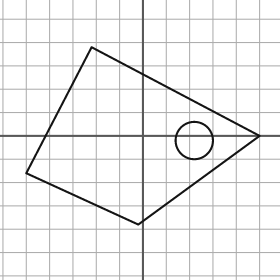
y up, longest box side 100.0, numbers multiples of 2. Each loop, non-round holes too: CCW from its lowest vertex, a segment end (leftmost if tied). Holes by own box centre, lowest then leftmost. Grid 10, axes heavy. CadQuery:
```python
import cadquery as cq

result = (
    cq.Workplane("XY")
    .moveTo(-2.0, -38.0)
    .lineTo(50.0, 0.0)
    .lineTo(-22.0, 38.0)
    .lineTo(-50.0, -16.0)
    .close()
    .moveTo(22.0, -2.0)
    .circle(8.0)
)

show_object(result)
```